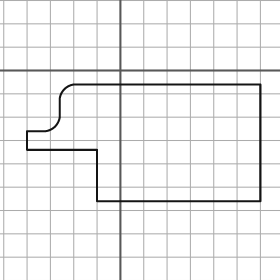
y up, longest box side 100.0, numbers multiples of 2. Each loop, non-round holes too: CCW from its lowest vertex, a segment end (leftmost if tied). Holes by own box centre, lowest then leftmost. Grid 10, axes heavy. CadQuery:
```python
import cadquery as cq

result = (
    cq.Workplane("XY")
    .moveTo(-10.0, -56.0)
    .lineTo(60.0, -56.0)
    .lineTo(60.0, -6.0)
    .lineTo(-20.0, -6.0)
    .threePointArc((-24.0, -8.0), (-26.0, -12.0))
    .lineTo(-26.0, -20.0)
    .threePointArc((-28.0, -24.0), (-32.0, -26.0))
    .lineTo(-40.0, -26.0)
    .lineTo(-40.0, -34.0)
    .lineTo(-10.0, -34.0)
    .close()
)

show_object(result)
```